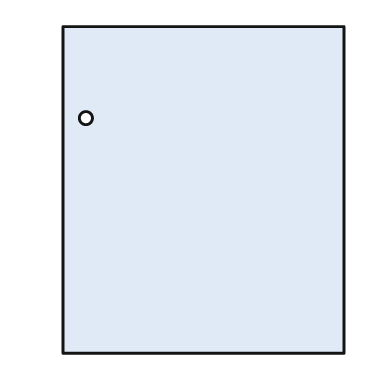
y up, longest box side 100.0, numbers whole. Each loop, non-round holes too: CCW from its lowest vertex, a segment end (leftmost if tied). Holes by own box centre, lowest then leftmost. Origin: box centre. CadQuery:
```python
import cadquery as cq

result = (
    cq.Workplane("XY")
    .moveTo(-43.0, -50.0)
    .lineTo(43.0, -50.0)
    .lineTo(43.0, 50.0)
    .lineTo(-43.0, 50.0)
    .close()
    .moveTo(-36.0, 22.0)
    .circle(2.0)
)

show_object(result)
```